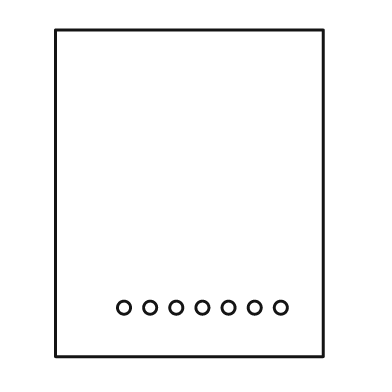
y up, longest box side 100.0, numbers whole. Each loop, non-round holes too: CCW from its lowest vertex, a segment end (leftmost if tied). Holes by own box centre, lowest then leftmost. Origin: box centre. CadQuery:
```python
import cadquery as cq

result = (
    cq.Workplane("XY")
    .moveTo(-41.0, -50.0)
    .lineTo(41.0, -50.0)
    .lineTo(41.0, 50.0)
    .lineTo(-41.0, 50.0)
    .close()
    .moveTo(-20.0, -35.0)
    .circle(2.0)
    .moveTo(-12.0, -35.0)
    .circle(2.0)
    .moveTo(-4.0, -35.0)
    .circle(2.0)
    .moveTo(4.0, -35.0)
    .circle(2.0)
    .moveTo(12.0, -35.0)
    .circle(2.0)
    .moveTo(20.0, -35.0)
    .circle(2.0)
    .moveTo(28.0, -35.0)
    .circle(2.0)
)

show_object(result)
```